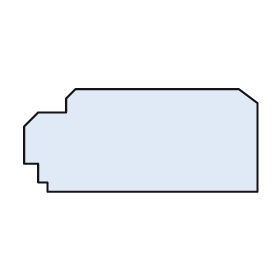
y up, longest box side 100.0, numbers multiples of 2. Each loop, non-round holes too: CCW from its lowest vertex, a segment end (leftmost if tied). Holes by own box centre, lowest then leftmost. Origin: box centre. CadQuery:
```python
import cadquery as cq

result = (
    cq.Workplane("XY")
    .moveTo(-40.0, -22.0)
    .lineTo(50.0, -22.0)
    .lineTo(50.0, 16.0)
    .lineTo(42.0, 22.0)
    .lineTo(-28.0, 22.0)
    .lineTo(-32.0, 18.0)
    .lineTo(-32.0, 12.0)
    .lineTo(-44.0, 12.0)
    .lineTo(-50.0, 6.0)
    .lineTo(-50.0, -10.0)
    .lineTo(-44.0, -10.0)
    .lineTo(-44.0, -18.0)
    .lineTo(-40.0, -18.0)
    .close()
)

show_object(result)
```